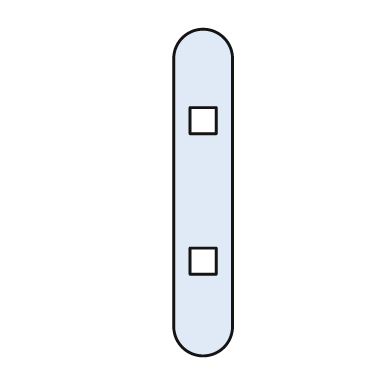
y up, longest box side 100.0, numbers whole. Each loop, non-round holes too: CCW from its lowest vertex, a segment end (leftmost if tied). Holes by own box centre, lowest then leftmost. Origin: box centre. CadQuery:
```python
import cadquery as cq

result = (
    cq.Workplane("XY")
    .moveTo(-9.0, -41.0)
    .threePointArc((0.0, -50.0), (9.0, -41.0))
    .lineTo(9.0, 41.0)
    .threePointArc((0.0, 50.0), (-9.0, 41.0))
    .close()
    .moveTo(-4.0, -25.0)
    .lineTo(4.0, -25.0)
    .lineTo(4.0, -17.0)
    .lineTo(-4.0, -17.0)
    .close()
    .moveTo(-4.0, 18.0)
    .lineTo(4.0, 18.0)
    .lineTo(4.0, 26.0)
    .lineTo(-4.0, 26.0)
    .close()
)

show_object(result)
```